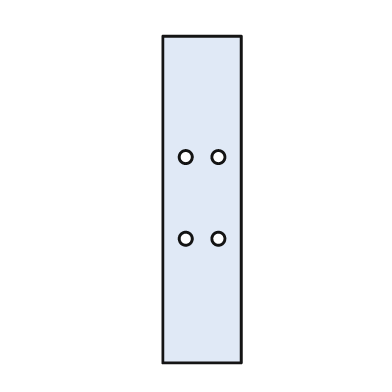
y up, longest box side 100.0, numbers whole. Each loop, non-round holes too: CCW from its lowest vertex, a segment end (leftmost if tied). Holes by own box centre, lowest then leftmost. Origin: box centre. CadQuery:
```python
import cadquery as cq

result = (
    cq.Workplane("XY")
    .moveTo(-12.0, -50.0)
    .lineTo(12.0, -50.0)
    .lineTo(12.0, 50.0)
    .lineTo(-12.0, 50.0)
    .close()
    .moveTo(-5.0, -12.0)
    .circle(2.0)
    .moveTo(5.0, -12.0)
    .circle(2.0)
    .moveTo(-5.0, 13.0)
    .circle(2.0)
    .moveTo(5.0, 13.0)
    .circle(2.0)
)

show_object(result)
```